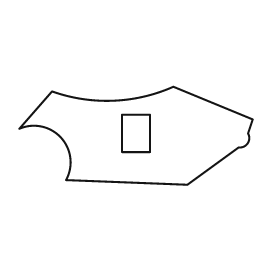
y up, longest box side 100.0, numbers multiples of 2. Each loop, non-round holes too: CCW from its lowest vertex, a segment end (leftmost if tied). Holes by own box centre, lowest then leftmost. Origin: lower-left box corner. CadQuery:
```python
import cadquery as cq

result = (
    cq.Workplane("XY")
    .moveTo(72.0, 0.0)
    .lineTo(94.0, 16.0)
    .threePointArc((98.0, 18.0), (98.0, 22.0))
    .lineTo(100.0, 28.0)
    .lineTo(66.0, 42.0)
    .threePointArc((40.0, 36.0), (14.0, 40.0))
    .lineTo(0.0, 24.0)
    .threePointArc((18.0, 20.0), (20.0, 2.0))
    .close()
    .moveTo(44.0, 14.0)
    .lineTo(56.0, 14.0)
    .lineTo(56.0, 30.0)
    .lineTo(44.0, 30.0)
    .close()
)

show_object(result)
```